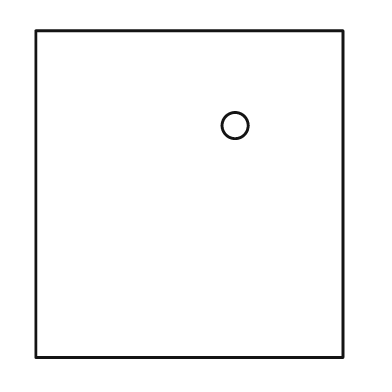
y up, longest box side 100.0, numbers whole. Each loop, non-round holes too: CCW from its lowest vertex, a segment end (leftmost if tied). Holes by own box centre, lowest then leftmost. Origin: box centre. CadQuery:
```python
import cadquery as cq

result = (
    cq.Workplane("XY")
    .moveTo(-47.0, -50.0)
    .lineTo(47.0, -50.0)
    .lineTo(47.0, 50.0)
    .lineTo(-47.0, 50.0)
    .close()
    .moveTo(14.0, 21.0)
    .circle(4.0)
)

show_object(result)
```